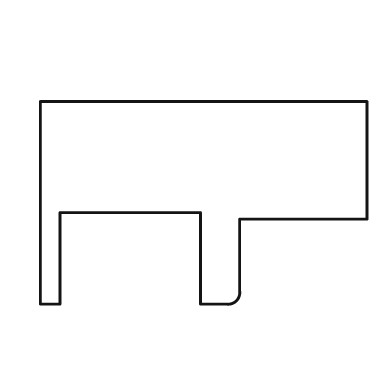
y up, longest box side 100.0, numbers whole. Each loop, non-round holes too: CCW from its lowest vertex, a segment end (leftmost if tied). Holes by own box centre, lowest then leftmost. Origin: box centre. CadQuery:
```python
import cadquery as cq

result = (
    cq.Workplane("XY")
    .moveTo(-50.0, -31.0)
    .lineTo(-44.0, -31.0)
    .lineTo(-44.0, -3.0)
    .lineTo(-1.0, -3.0)
    .lineTo(-1.0, -31.0)
    .lineTo(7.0, -31.0)
    .threePointArc((10.0, -30.0), (11.0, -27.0))
    .lineTo(11.0, -5.0)
    .lineTo(50.0, -5.0)
    .lineTo(50.0, 31.0)
    .lineTo(-50.0, 31.0)
    .close()
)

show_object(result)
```